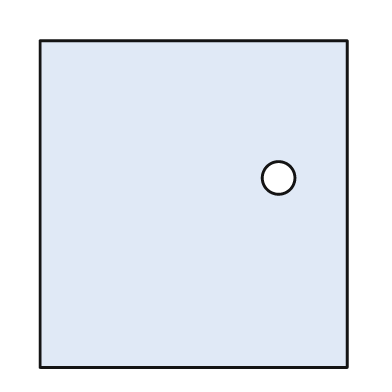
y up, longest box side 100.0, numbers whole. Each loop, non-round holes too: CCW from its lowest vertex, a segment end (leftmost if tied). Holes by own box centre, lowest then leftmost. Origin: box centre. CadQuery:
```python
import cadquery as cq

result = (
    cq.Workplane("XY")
    .moveTo(-47.0, -50.0)
    .lineTo(47.0, -50.0)
    .lineTo(47.0, 50.0)
    .lineTo(-47.0, 50.0)
    .close()
    .moveTo(26.0, 8.0)
    .circle(5.0)
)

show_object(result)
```